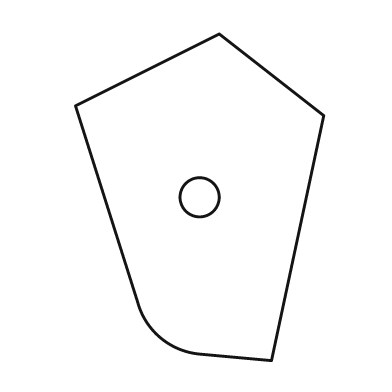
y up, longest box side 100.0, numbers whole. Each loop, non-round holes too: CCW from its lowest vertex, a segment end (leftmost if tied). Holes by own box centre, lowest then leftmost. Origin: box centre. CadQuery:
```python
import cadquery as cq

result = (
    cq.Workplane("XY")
    .moveTo(22.0, -50.0)
    .lineTo(38.0, 25.0)
    .lineTo(6.0, 50.0)
    .lineTo(-38.0, 28.0)
    .lineTo(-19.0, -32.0)
    .threePointArc((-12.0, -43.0), (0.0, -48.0))
    .close()
    .moveTo(0.0, 0.0)
    .circle(6.0)
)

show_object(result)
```